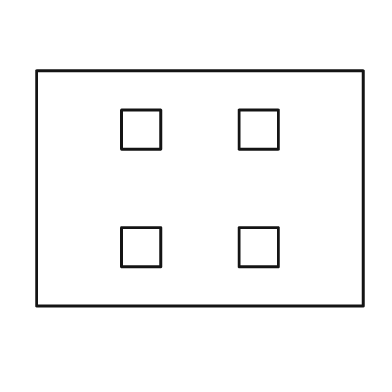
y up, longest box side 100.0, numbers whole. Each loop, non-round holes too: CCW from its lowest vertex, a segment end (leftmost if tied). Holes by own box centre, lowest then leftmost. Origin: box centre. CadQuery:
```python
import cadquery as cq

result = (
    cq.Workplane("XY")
    .moveTo(-50.0, -36.0)
    .lineTo(50.0, -36.0)
    .lineTo(50.0, 36.0)
    .lineTo(-50.0, 36.0)
    .close()
    .moveTo(-24.0, -24.0)
    .lineTo(-12.0, -24.0)
    .lineTo(-12.0, -12.0)
    .lineTo(-24.0, -12.0)
    .close()
    .moveTo(12.0, -24.0)
    .lineTo(24.0, -24.0)
    .lineTo(24.0, -12.0)
    .lineTo(12.0, -12.0)
    .close()
    .moveTo(-24.0, 12.0)
    .lineTo(-12.0, 12.0)
    .lineTo(-12.0, 24.0)
    .lineTo(-24.0, 24.0)
    .close()
    .moveTo(12.0, 12.0)
    .lineTo(24.0, 12.0)
    .lineTo(24.0, 24.0)
    .lineTo(12.0, 24.0)
    .close()
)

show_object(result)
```